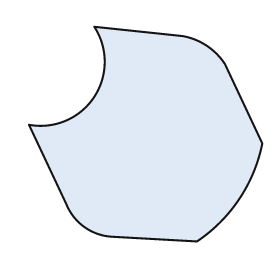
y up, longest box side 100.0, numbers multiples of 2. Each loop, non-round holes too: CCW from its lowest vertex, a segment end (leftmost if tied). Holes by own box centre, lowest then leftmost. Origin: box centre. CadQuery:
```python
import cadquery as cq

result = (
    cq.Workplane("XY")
    .moveTo(22.0, -46.0)
    .threePointArc((40.0, -28.0), (50.0, -4.0))
    .lineTo(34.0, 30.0)
    .threePointArc((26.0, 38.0), (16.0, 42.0))
    .lineTo(-22.0, 46.0)
    .threePointArc((-22.0, 16.0), (-50.0, 4.0))
    .lineTo(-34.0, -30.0)
    .threePointArc((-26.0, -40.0), (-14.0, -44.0))
    .close()
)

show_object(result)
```